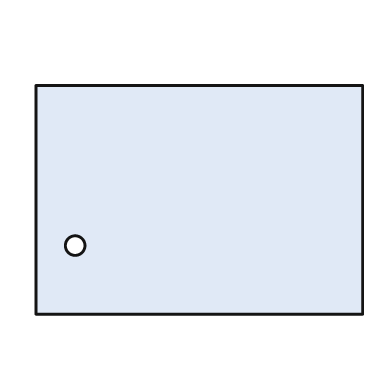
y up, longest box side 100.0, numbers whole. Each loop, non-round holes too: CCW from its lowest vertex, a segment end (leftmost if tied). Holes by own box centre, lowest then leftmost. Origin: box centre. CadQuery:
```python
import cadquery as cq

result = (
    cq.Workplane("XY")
    .moveTo(-50.0, -35.0)
    .lineTo(50.0, -35.0)
    .lineTo(50.0, 35.0)
    .lineTo(-50.0, 35.0)
    .close()
    .moveTo(-38.0, -14.0)
    .circle(3.0)
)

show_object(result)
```